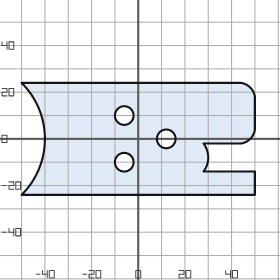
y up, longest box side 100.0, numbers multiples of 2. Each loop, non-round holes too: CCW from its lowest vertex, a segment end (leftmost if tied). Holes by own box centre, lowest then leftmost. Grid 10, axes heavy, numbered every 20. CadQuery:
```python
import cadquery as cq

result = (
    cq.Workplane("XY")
    .moveTo(-50.0, -24.0)
    .lineTo(50.0, -24.0)
    .lineTo(50.0, -14.0)
    .lineTo(28.0, -14.0)
    .threePointArc((30.0, -8.0), (28.0, -2.0))
    .lineTo(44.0, -2.0)
    .threePointArc((48.0, 0.0), (50.0, 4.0))
    .lineTo(50.0, 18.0)
    .threePointArc((48.0, 22.0), (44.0, 24.0))
    .lineTo(-50.0, 24.0)
    .threePointArc((-40.0, 0.0), (-50.0, -24.0))
    .close()
    .moveTo(-6.0, -10.0)
    .circle(4.0)
    .moveTo(12.0, 0.0)
    .circle(4.0)
    .moveTo(-6.0, 10.0)
    .circle(4.0)
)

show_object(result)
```